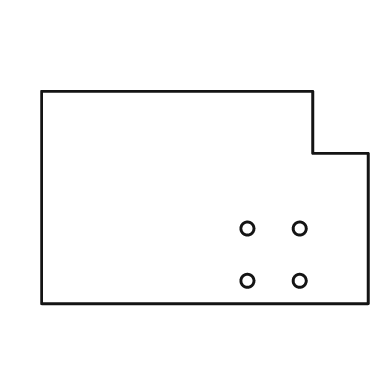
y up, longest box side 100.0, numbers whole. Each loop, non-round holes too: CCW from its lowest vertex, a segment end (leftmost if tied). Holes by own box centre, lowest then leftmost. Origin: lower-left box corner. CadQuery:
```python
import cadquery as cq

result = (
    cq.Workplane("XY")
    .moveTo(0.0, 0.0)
    .lineTo(100.0, 0.0)
    .lineTo(100.0, 46.0)
    .lineTo(83.0, 46.0)
    .lineTo(83.0, 65.0)
    .lineTo(0.0, 65.0)
    .close()
    .moveTo(63.0, 7.0)
    .circle(2.0)
    .moveTo(79.0, 7.0)
    .circle(2.0)
    .moveTo(63.0, 23.0)
    .circle(2.0)
    .moveTo(79.0, 23.0)
    .circle(2.0)
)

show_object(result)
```